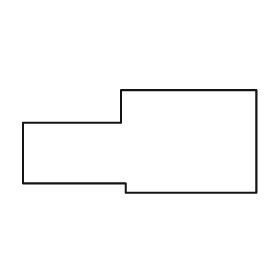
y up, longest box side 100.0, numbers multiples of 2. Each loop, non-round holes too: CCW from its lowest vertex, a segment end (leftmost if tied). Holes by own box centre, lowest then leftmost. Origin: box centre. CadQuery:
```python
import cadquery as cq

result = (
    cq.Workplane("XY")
    .moveTo(-6.0, -22.0)
    .lineTo(50.0, -22.0)
    .lineTo(50.0, 22.0)
    .lineTo(-8.0, 22.0)
    .lineTo(-8.0, 8.0)
    .lineTo(-50.0, 8.0)
    .lineTo(-50.0, -18.0)
    .lineTo(-6.0, -18.0)
    .close()
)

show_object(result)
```